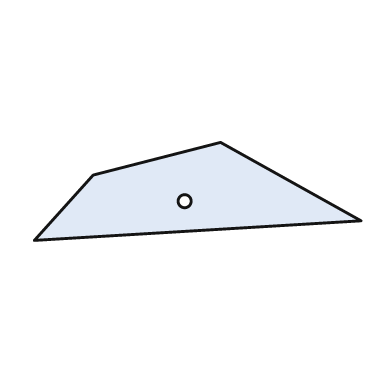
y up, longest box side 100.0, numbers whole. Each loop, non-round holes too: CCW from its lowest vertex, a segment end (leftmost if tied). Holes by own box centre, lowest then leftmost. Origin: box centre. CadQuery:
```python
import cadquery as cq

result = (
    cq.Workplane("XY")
    .moveTo(-50.0, -15.0)
    .lineTo(50.0, -9.0)
    .lineTo(7.0, 15.0)
    .lineTo(-32.0, 5.0)
    .close()
    .moveTo(-4.0, -3.0)
    .circle(2.0)
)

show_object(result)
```